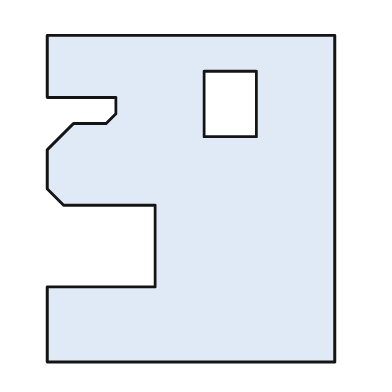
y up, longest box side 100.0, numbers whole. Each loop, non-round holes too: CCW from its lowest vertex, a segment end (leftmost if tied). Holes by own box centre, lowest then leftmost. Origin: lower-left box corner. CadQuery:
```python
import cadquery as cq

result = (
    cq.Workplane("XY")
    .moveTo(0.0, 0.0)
    .lineTo(88.0, 0.0)
    .lineTo(88.0, 100.0)
    .lineTo(0.0, 100.0)
    .lineTo(0.0, 81.0)
    .lineTo(21.0, 81.0)
    .lineTo(21.0, 76.0)
    .lineTo(18.0, 73.0)
    .lineTo(8.0, 73.0)
    .lineTo(0.0, 65.0)
    .lineTo(0.0, 53.0)
    .lineTo(5.0, 48.0)
    .lineTo(33.0, 48.0)
    .lineTo(33.0, 23.0)
    .lineTo(0.0, 23.0)
    .close()
    .moveTo(48.0, 69.0)
    .lineTo(64.0, 69.0)
    .lineTo(64.0, 89.0)
    .lineTo(48.0, 89.0)
    .close()
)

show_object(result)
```